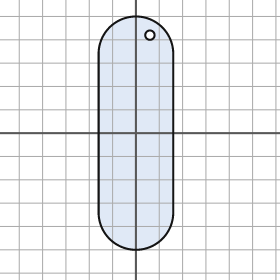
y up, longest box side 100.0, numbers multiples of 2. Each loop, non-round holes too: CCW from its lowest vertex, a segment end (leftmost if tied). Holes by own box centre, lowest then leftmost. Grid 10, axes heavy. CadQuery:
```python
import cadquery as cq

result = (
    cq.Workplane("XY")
    .moveTo(-16.0, -34.0)
    .threePointArc((0.0, -50.0), (16.0, -34.0))
    .lineTo(16.0, 34.0)
    .threePointArc((0.0, 50.0), (-16.0, 34.0))
    .close()
    .moveTo(6.0, 42.0)
    .circle(2.0)
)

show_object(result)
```